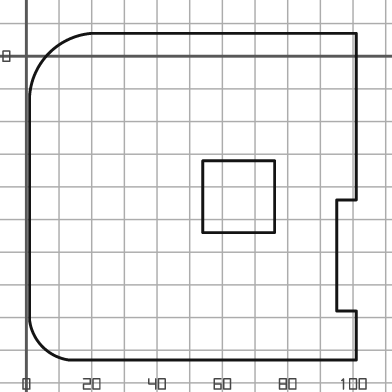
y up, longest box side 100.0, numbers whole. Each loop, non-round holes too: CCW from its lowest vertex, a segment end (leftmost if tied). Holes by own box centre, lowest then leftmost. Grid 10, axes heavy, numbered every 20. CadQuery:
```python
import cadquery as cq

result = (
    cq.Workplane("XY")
    .moveTo(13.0, -93.0)
    .lineTo(101.0, -93.0)
    .lineTo(101.0, -78.0)
    .lineTo(95.0, -78.0)
    .lineTo(95.0, -44.0)
    .lineTo(101.0, -44.0)
    .lineTo(101.0, 7.0)
    .lineTo(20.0, 7.0)
    .threePointArc((7.0, 1.0), (1.0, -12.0))
    .lineTo(1.0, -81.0)
    .threePointArc((5.0, -89.0), (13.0, -93.0))
    .close()
    .moveTo(54.0, -54.0)
    .lineTo(76.0, -54.0)
    .lineTo(76.0, -32.0)
    .lineTo(54.0, -32.0)
    .close()
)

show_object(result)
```